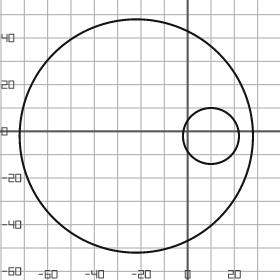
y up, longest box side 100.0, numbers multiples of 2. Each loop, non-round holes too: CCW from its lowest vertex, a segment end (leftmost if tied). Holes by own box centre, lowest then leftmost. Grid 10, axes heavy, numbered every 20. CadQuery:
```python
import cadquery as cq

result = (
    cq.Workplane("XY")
    .moveTo(-22.0, -2.0)
    .circle(50.0)
    .moveTo(10.0, -2.0)
    .circle(12.0)
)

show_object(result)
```